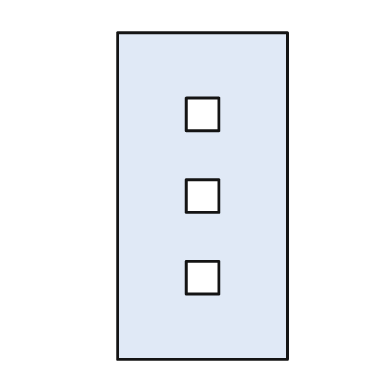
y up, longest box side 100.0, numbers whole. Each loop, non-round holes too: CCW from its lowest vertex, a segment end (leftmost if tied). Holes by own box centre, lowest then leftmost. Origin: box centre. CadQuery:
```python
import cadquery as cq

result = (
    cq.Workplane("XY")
    .moveTo(-26.0, -50.0)
    .lineTo(26.0, -50.0)
    .lineTo(26.0, 50.0)
    .lineTo(-26.0, 50.0)
    .close()
    .moveTo(-5.0, -30.0)
    .lineTo(5.0, -30.0)
    .lineTo(5.0, -20.0)
    .lineTo(-5.0, -20.0)
    .close()
    .moveTo(-5.0, -5.0)
    .lineTo(5.0, -5.0)
    .lineTo(5.0, 5.0)
    .lineTo(-5.0, 5.0)
    .close()
    .moveTo(-5.0, 20.0)
    .lineTo(5.0, 20.0)
    .lineTo(5.0, 30.0)
    .lineTo(-5.0, 30.0)
    .close()
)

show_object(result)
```